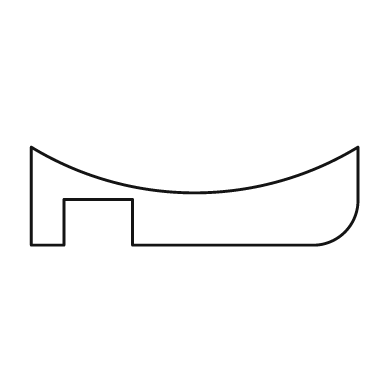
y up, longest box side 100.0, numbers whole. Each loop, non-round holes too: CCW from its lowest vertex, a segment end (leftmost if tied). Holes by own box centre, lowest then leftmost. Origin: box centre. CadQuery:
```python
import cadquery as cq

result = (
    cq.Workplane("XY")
    .moveTo(-50.0, -15.0)
    .lineTo(-40.0, -15.0)
    .lineTo(-40.0, -1.0)
    .lineTo(-19.0, -1.0)
    .lineTo(-19.0, -15.0)
    .lineTo(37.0, -15.0)
    .threePointArc((46.0, -11.0), (50.0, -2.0))
    .lineTo(50.0, 15.0)
    .threePointArc((0.0, 1.0), (-50.0, 15.0))
    .close()
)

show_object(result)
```